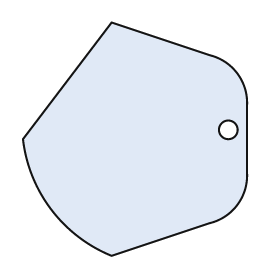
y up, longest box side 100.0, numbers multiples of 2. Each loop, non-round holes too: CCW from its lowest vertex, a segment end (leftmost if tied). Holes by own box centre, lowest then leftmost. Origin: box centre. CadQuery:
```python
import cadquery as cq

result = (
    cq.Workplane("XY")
    .moveTo(-10.0, -50.0)
    .lineTo(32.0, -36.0)
    .threePointArc((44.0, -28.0), (48.0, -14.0))
    .lineTo(48.0, 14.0)
    .threePointArc((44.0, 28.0), (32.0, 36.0))
    .lineTo(-10.0, 50.0)
    .lineTo(-48.0, 0.0)
    .threePointArc((-36.0, -30.0), (-10.0, -50.0))
    .close()
    .moveTo(40.0, 4.0)
    .circle(4.0)
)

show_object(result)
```